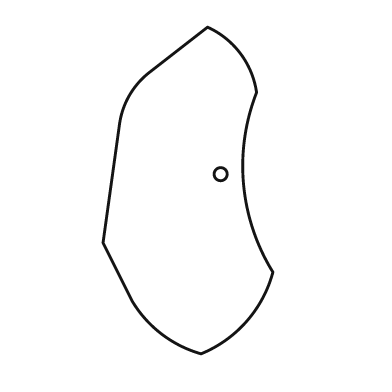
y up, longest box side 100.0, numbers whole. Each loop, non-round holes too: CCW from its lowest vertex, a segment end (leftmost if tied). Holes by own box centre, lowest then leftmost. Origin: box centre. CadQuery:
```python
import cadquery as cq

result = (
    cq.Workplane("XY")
    .moveTo(4.0, -50.0)
    .threePointArc((18.0, -40.0), (26.0, -25.0))
    .threePointArc((17.0, 2.0), (21.0, 30.0))
    .threePointArc((16.0, 42.0), (6.0, 50.0))
    .lineTo(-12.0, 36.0)
    .threePointArc((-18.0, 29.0), (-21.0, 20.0))
    .lineTo(-26.0, -16.0)
    .lineTo(-17.0, -34.0)
    .threePointArc((-8.0, -44.0), (4.0, -50.0))
    .close()
    .moveTo(10.0, 5.0)
    .circle(2.0)
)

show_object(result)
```